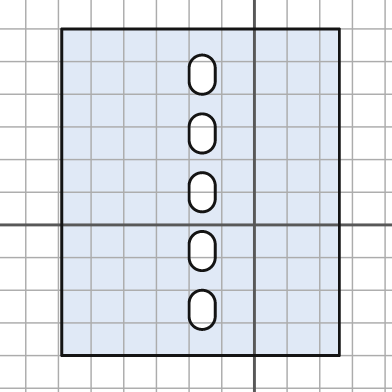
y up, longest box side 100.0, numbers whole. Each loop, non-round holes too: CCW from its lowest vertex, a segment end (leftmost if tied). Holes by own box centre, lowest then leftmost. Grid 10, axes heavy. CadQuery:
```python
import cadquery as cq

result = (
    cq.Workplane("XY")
    .moveTo(-59.0, -40.0)
    .lineTo(26.0, -40.0)
    .lineTo(26.0, 60.0)
    .lineTo(-59.0, 60.0)
    .close()
    .moveTo(-20.0, -28.0)
    .threePointArc((-16.0, -32.0), (-12.0, -28.0))
    .lineTo(-12.0, -24.0)
    .threePointArc((-16.0, -20.0), (-20.0, -24.0))
    .close()
    .moveTo(-20.0, -10.0)
    .threePointArc((-16.0, -14.0), (-12.0, -10.0))
    .lineTo(-12.0, -6.0)
    .threePointArc((-16.0, -2.0), (-20.0, -6.0))
    .close()
    .moveTo(-20.0, 8.0)
    .threePointArc((-16.0, 4.0), (-12.0, 8.0))
    .lineTo(-12.0, 12.0)
    .threePointArc((-16.0, 16.0), (-20.0, 12.0))
    .close()
    .moveTo(-20.0, 26.0)
    .threePointArc((-16.0, 22.0), (-12.0, 26.0))
    .lineTo(-12.0, 30.0)
    .threePointArc((-16.0, 34.0), (-20.0, 30.0))
    .close()
    .moveTo(-20.0, 44.0)
    .threePointArc((-16.0, 40.0), (-12.0, 44.0))
    .lineTo(-12.0, 48.0)
    .threePointArc((-16.0, 52.0), (-20.0, 48.0))
    .close()
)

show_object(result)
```